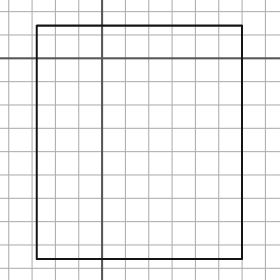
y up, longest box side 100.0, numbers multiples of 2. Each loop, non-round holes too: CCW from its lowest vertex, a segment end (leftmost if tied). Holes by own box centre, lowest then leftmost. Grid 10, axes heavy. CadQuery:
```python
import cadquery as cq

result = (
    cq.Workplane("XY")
    .moveTo(-28.0, -86.0)
    .lineTo(60.0, -86.0)
    .lineTo(60.0, 14.0)
    .lineTo(-28.0, 14.0)
    .close()
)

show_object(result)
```